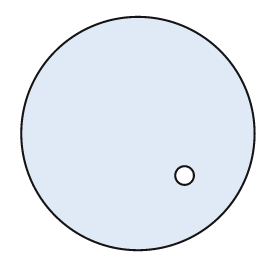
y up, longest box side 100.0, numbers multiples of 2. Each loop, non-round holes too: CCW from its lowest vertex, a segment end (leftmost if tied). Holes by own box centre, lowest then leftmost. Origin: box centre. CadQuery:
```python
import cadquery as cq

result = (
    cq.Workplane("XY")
    .moveTo(0.0, 0.0)
    .circle(50.0)
    .moveTo(20.0, -18.0)
    .circle(4.0)
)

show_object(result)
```